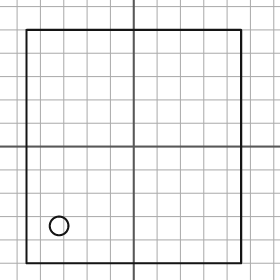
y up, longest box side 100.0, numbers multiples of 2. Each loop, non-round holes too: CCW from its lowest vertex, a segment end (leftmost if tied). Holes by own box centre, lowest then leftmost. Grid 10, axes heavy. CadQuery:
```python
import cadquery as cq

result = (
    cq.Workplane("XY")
    .moveTo(-46.0, -50.0)
    .lineTo(46.0, -50.0)
    .lineTo(46.0, 50.0)
    .lineTo(-46.0, 50.0)
    .close()
    .moveTo(-32.0, -34.0)
    .circle(4.0)
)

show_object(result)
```